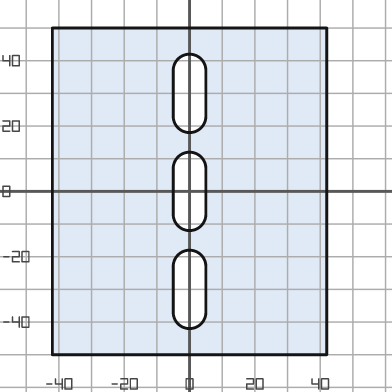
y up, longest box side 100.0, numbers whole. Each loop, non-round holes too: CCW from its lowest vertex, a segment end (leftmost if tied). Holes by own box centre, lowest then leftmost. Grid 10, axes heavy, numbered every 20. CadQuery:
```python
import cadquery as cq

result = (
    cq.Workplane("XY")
    .moveTo(-42.0, -50.0)
    .lineTo(42.0, -50.0)
    .lineTo(42.0, 50.0)
    .lineTo(-42.0, 50.0)
    .close()
    .moveTo(-5.0, -37.0)
    .threePointArc((0.0, -42.0), (5.0, -37.0))
    .lineTo(5.0, -23.0)
    .threePointArc((0.0, -18.0), (-5.0, -23.0))
    .close()
    .moveTo(-5.0, -7.0)
    .threePointArc((0.0, -12.0), (5.0, -7.0))
    .lineTo(5.0, 7.0)
    .threePointArc((0.0, 12.0), (-5.0, 7.0))
    .close()
    .moveTo(-5.0, 23.0)
    .threePointArc((0.0, 18.0), (5.0, 23.0))
    .lineTo(5.0, 37.0)
    .threePointArc((0.0, 42.0), (-5.0, 37.0))
    .close()
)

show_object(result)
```